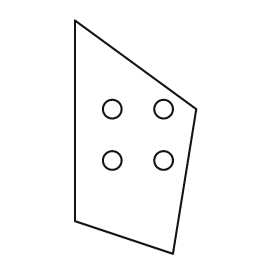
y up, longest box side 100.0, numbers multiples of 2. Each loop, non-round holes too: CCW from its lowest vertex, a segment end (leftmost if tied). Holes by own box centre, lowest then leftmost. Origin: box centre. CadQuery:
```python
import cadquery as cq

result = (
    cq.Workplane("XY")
    .moveTo(16.0, -50.0)
    .lineTo(26.0, 12.0)
    .lineTo(-26.0, 50.0)
    .lineTo(-26.0, -36.0)
    .close()
    .moveTo(-10.0, -10.0)
    .circle(4.0)
    .moveTo(12.0, -10.0)
    .circle(4.0)
    .moveTo(-10.0, 12.0)
    .circle(4.0)
    .moveTo(12.0, 12.0)
    .circle(4.0)
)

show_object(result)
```